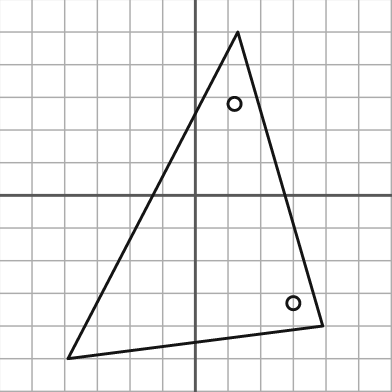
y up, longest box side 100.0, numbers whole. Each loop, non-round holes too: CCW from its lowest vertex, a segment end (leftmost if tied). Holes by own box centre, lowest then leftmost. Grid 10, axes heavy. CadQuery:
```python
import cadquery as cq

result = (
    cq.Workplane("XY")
    .moveTo(-39.0, -50.0)
    .lineTo(39.0, -40.0)
    .lineTo(13.0, 50.0)
    .close()
    .moveTo(30.0, -33.0)
    .circle(2.0)
    .moveTo(12.0, 28.0)
    .circle(2.0)
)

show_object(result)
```